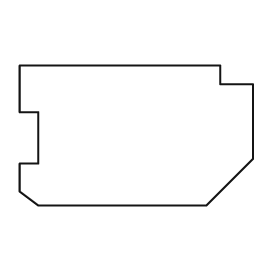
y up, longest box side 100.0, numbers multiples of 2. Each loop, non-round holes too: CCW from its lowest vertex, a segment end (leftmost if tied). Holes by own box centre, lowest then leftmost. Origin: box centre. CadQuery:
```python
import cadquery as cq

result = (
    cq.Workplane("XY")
    .moveTo(-42.0, -30.0)
    .lineTo(30.0, -30.0)
    .lineTo(50.0, -10.0)
    .lineTo(50.0, 22.0)
    .lineTo(36.0, 22.0)
    .lineTo(36.0, 30.0)
    .lineTo(-50.0, 30.0)
    .lineTo(-50.0, 10.0)
    .lineTo(-42.0, 10.0)
    .lineTo(-42.0, -12.0)
    .lineTo(-50.0, -12.0)
    .lineTo(-50.0, -24.0)
    .close()
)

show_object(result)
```